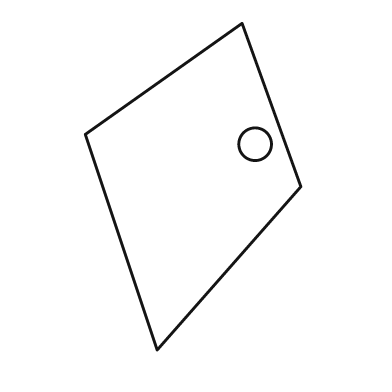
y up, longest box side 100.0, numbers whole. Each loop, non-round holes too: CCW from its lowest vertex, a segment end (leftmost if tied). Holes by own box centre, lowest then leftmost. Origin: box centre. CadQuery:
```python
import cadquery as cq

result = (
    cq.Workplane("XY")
    .moveTo(-11.0, -50.0)
    .lineTo(33.0, 0.0)
    .lineTo(15.0, 50.0)
    .lineTo(-33.0, 16.0)
    .close()
    .moveTo(19.0, 13.0)
    .circle(5.0)
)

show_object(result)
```